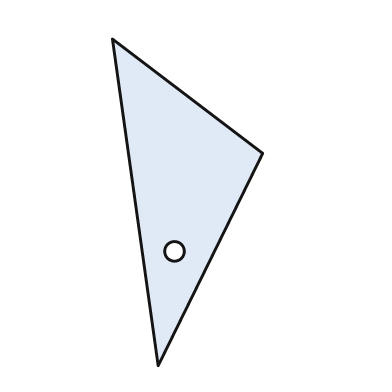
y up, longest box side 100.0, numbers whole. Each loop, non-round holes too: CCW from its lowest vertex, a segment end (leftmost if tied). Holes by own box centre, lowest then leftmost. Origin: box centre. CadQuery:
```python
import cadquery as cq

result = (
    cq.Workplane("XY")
    .moveTo(-9.0, -50.0)
    .lineTo(23.0, 15.0)
    .lineTo(-23.0, 50.0)
    .close()
    .moveTo(-4.0, -15.0)
    .circle(3.0)
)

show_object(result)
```